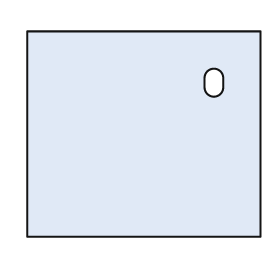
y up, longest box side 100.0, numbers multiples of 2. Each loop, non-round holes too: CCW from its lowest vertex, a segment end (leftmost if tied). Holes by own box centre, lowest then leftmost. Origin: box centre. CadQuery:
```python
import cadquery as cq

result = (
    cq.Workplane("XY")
    .moveTo(-50.0, -44.0)
    .lineTo(50.0, -44.0)
    .lineTo(50.0, 44.0)
    .lineTo(-50.0, 44.0)
    .close()
    .moveTo(26.0, 20.0)
    .threePointArc((30.0, 16.0), (34.0, 20.0))
    .lineTo(34.0, 24.0)
    .threePointArc((30.0, 28.0), (26.0, 24.0))
    .close()
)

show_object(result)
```